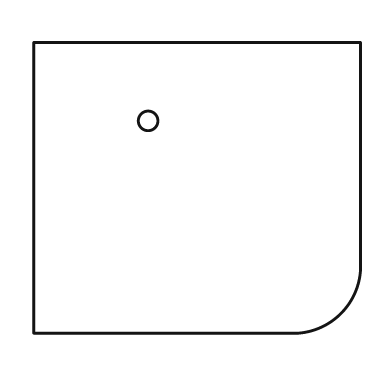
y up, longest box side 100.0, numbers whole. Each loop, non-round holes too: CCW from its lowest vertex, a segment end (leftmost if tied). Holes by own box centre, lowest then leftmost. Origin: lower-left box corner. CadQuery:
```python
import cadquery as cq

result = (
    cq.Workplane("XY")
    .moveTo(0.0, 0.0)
    .lineTo(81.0, 0.0)
    .threePointArc((94.0, 6.0), (100.0, 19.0))
    .lineTo(100.0, 89.0)
    .lineTo(0.0, 89.0)
    .close()
    .moveTo(35.0, 65.0)
    .circle(3.0)
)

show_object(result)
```